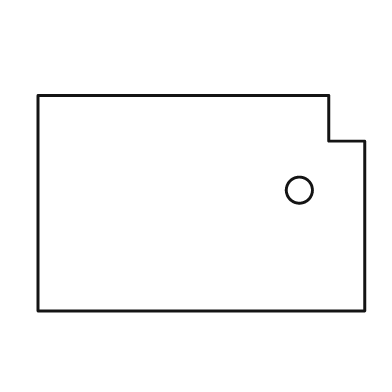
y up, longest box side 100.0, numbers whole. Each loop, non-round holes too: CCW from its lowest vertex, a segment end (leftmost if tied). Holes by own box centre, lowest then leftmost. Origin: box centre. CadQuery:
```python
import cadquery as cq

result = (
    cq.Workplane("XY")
    .moveTo(-50.0, -33.0)
    .lineTo(50.0, -33.0)
    .lineTo(50.0, 19.0)
    .lineTo(39.0, 19.0)
    .lineTo(39.0, 33.0)
    .lineTo(-50.0, 33.0)
    .close()
    .moveTo(30.0, 4.0)
    .circle(4.0)
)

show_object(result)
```